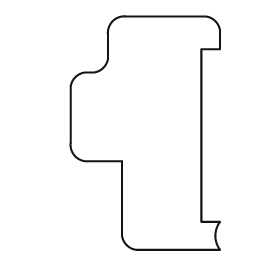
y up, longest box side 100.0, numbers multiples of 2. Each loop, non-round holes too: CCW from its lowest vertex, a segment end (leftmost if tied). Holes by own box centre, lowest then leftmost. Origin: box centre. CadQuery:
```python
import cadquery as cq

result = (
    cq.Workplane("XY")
    .moveTo(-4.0, -50.0)
    .lineTo(32.0, -50.0)
    .threePointArc((30.0, -44.0), (32.0, -38.0))
    .lineTo(24.0, -38.0)
    .lineTo(24.0, 36.0)
    .lineTo(32.0, 36.0)
    .lineTo(32.0, 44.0)
    .threePointArc((30.0, 48.0), (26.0, 50.0))
    .lineTo(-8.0, 50.0)
    .threePointArc((-14.0, 48.0), (-16.0, 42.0))
    .lineTo(-16.0, 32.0)
    .threePointArc((-18.0, 28.0), (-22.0, 26.0))
    .lineTo(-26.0, 26.0)
    .threePointArc((-30.0, 24.0), (-32.0, 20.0))
    .lineTo(-32.0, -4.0)
    .threePointArc((-30.0, -10.0), (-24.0, -12.0))
    .lineTo(-10.0, -12.0)
    .lineTo(-10.0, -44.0)
    .threePointArc((-8.0, -48.0), (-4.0, -50.0))
    .close()
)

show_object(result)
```